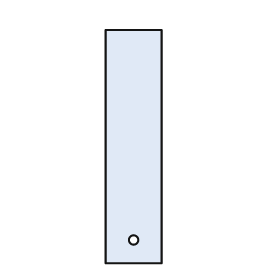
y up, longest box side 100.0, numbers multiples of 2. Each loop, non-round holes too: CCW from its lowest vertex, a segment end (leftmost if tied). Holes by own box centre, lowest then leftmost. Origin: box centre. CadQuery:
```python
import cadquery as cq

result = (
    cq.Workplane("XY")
    .moveTo(-12.0, -50.0)
    .lineTo(12.0, -50.0)
    .lineTo(12.0, 50.0)
    .lineTo(-12.0, 50.0)
    .close()
    .moveTo(0.0, -40.0)
    .circle(2.0)
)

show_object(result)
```